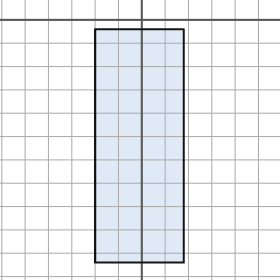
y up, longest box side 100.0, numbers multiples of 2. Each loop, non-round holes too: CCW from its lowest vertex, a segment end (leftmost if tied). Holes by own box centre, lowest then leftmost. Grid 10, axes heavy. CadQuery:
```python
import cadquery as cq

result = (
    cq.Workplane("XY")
    .moveTo(-20.0, -104.0)
    .lineTo(18.0, -104.0)
    .lineTo(18.0, -4.0)
    .lineTo(-20.0, -4.0)
    .close()
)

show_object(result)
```